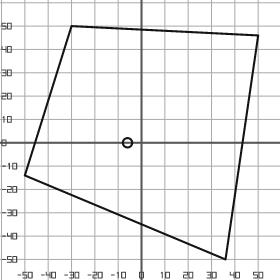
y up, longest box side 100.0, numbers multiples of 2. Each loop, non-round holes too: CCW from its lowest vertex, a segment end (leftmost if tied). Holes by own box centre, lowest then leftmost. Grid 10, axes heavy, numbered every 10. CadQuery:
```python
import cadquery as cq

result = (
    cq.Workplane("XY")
    .moveTo(36.0, -50.0)
    .lineTo(50.0, 46.0)
    .lineTo(-30.0, 50.0)
    .lineTo(-50.0, -14.0)
    .close()
    .moveTo(-6.0, 0.0)
    .circle(2.0)
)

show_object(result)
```